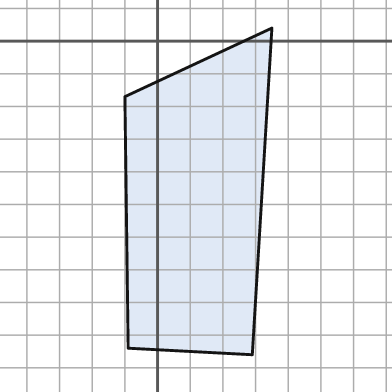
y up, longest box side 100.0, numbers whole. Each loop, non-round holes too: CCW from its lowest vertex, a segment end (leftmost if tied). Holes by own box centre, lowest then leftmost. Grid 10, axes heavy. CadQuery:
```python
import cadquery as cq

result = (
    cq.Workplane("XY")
    .moveTo(29.0, -96.0)
    .lineTo(35.0, 4.0)
    .lineTo(-10.0, -17.0)
    .lineTo(-9.0, -94.0)
    .close()
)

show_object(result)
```